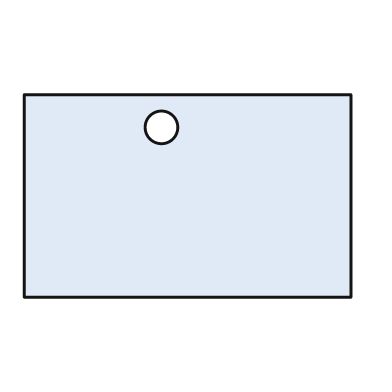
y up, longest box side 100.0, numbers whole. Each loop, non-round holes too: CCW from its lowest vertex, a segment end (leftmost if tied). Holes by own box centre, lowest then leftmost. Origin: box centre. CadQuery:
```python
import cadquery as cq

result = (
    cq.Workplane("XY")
    .moveTo(-50.0, -31.0)
    .lineTo(50.0, -31.0)
    .lineTo(50.0, 31.0)
    .lineTo(-50.0, 31.0)
    .close()
    .moveTo(-8.0, 21.0)
    .circle(5.0)
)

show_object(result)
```